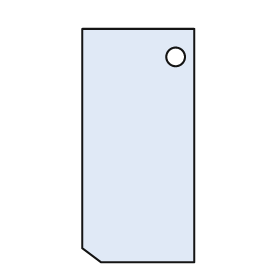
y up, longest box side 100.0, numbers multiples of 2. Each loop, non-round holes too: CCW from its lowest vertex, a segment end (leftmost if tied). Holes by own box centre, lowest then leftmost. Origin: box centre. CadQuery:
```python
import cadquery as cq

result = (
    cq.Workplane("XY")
    .moveTo(-16.0, -50.0)
    .lineTo(24.0, -50.0)
    .lineTo(24.0, 50.0)
    .lineTo(-24.0, 50.0)
    .lineTo(-24.0, -44.0)
    .close()
    .moveTo(16.0, 38.0)
    .circle(4.0)
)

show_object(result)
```